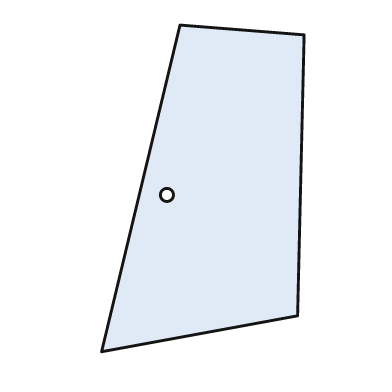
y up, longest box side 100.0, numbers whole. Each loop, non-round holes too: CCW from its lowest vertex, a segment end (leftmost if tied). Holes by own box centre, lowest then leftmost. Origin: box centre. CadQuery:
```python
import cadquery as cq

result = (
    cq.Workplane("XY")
    .moveTo(-31.0, -50.0)
    .lineTo(29.0, -39.0)
    .lineTo(31.0, 47.0)
    .lineTo(-7.0, 50.0)
    .close()
    .moveTo(-11.0, -2.0)
    .circle(2.0)
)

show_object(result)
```